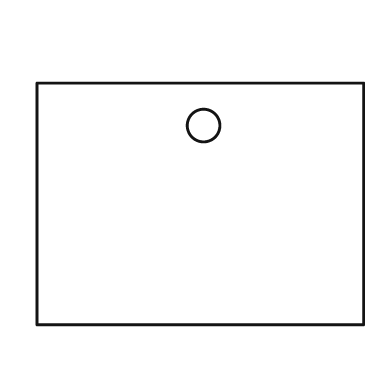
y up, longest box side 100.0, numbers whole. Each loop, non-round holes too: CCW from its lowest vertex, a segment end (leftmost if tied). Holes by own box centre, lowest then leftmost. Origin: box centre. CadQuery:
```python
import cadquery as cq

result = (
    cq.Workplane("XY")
    .moveTo(-50.0, -37.0)
    .lineTo(50.0, -37.0)
    .lineTo(50.0, 37.0)
    .lineTo(-50.0, 37.0)
    .close()
    .moveTo(1.0, 24.0)
    .circle(5.0)
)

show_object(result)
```